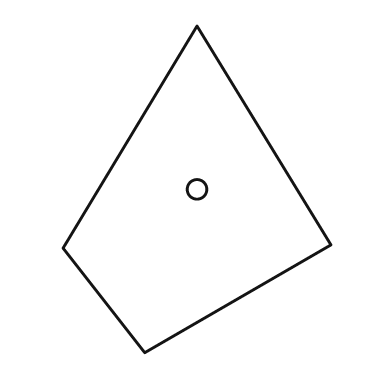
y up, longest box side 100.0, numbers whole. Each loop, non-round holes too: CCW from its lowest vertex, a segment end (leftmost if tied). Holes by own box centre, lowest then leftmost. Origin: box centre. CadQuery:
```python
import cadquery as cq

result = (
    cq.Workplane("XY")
    .moveTo(-16.0, -50.0)
    .lineTo(41.0, -17.0)
    .lineTo(0.0, 50.0)
    .lineTo(-41.0, -18.0)
    .close()
    .moveTo(0.0, 0.0)
    .circle(3.0)
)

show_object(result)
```